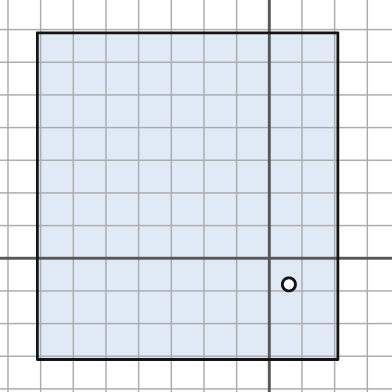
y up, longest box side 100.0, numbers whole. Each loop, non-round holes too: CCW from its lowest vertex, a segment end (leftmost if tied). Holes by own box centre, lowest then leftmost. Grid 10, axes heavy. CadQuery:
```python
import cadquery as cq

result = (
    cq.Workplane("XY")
    .moveTo(-71.0, -31.0)
    .lineTo(21.0, -31.0)
    .lineTo(21.0, 69.0)
    .lineTo(-71.0, 69.0)
    .close()
    .moveTo(6.0, -8.0)
    .circle(2.0)
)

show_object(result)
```